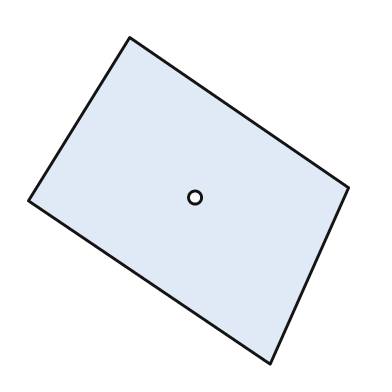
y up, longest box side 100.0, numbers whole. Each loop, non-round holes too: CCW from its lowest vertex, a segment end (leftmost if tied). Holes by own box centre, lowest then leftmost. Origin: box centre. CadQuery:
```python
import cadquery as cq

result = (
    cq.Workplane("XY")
    .moveTo(25.0, -50.0)
    .lineTo(49.0, 4.0)
    .lineTo(-18.0, 50.0)
    .lineTo(-49.0, 0.0)
    .close()
    .moveTo(2.0, 1.0)
    .circle(2.0)
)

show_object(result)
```